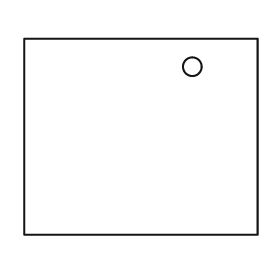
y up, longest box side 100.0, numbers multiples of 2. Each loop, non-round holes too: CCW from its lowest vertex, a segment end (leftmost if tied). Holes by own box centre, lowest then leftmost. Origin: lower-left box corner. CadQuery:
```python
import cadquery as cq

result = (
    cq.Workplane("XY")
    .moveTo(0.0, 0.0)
    .lineTo(100.0, 0.0)
    .lineTo(100.0, 84.0)
    .lineTo(0.0, 84.0)
    .close()
    .moveTo(72.0, 72.0)
    .circle(4.0)
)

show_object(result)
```